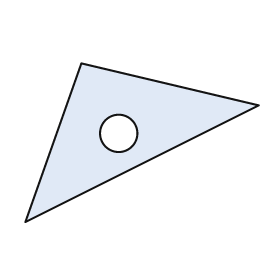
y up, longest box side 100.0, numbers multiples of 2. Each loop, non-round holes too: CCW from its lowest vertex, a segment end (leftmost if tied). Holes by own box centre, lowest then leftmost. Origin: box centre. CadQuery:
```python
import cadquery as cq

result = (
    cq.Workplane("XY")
    .moveTo(-50.0, -34.0)
    .lineTo(50.0, 16.0)
    .lineTo(-26.0, 34.0)
    .close()
    .moveTo(-10.0, 4.0)
    .circle(8.0)
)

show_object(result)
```